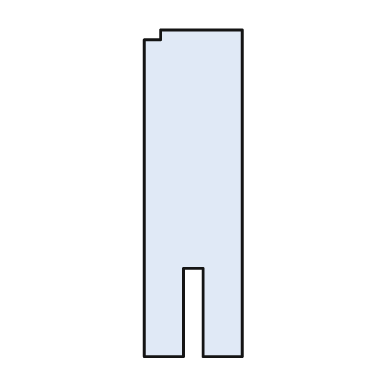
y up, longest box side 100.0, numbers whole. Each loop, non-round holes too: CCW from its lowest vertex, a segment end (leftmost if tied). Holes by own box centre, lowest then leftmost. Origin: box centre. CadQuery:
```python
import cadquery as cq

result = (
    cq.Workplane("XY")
    .moveTo(-15.0, -50.0)
    .lineTo(-3.0, -50.0)
    .lineTo(-3.0, -23.0)
    .lineTo(3.0, -23.0)
    .lineTo(3.0, -50.0)
    .lineTo(15.0, -50.0)
    .lineTo(15.0, 50.0)
    .lineTo(-10.0, 50.0)
    .lineTo(-10.0, 47.0)
    .lineTo(-15.0, 47.0)
    .close()
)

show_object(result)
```